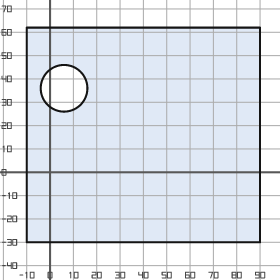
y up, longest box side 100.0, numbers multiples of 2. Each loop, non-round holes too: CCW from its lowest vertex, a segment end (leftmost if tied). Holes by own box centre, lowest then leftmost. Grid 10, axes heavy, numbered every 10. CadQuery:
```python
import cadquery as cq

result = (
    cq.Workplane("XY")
    .moveTo(-10.0, -30.0)
    .lineTo(90.0, -30.0)
    .lineTo(90.0, 62.0)
    .lineTo(-10.0, 62.0)
    .close()
    .moveTo(6.0, 36.0)
    .circle(10.0)
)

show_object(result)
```